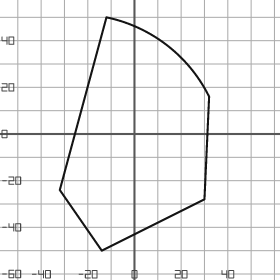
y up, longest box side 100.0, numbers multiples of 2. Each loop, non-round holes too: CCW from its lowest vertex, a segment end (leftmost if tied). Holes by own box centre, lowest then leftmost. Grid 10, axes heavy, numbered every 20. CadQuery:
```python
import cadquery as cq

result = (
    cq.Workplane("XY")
    .moveTo(-14.0, -50.0)
    .lineTo(30.0, -28.0)
    .lineTo(32.0, 16.0)
    .threePointArc((14.0, 38.0), (-12.0, 50.0))
    .lineTo(-32.0, -24.0)
    .close()
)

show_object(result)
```